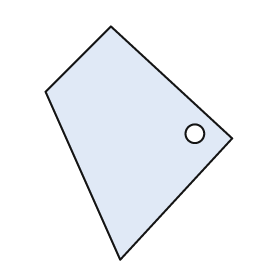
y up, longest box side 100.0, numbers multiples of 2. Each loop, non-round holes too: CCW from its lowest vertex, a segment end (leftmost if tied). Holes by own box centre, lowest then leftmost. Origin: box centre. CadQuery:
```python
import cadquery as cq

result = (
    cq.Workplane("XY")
    .moveTo(-8.0, -50.0)
    .lineTo(40.0, 2.0)
    .lineTo(-12.0, 50.0)
    .lineTo(-40.0, 22.0)
    .close()
    .moveTo(24.0, 4.0)
    .circle(4.0)
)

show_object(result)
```